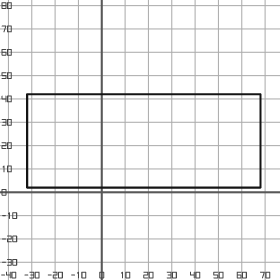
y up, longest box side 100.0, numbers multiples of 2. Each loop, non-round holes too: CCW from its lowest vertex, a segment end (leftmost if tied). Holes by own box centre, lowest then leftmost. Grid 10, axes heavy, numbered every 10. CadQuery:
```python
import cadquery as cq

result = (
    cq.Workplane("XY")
    .moveTo(-32.0, 2.0)
    .lineTo(68.0, 2.0)
    .lineTo(68.0, 42.0)
    .lineTo(-32.0, 42.0)
    .close()
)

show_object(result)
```